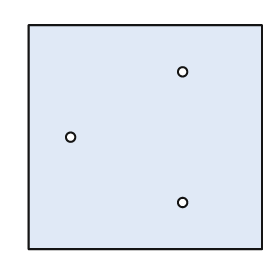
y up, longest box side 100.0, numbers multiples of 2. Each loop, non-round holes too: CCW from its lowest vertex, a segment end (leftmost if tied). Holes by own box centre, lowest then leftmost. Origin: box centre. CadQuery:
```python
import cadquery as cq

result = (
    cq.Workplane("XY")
    .moveTo(-50.0, -48.0)
    .lineTo(50.0, -48.0)
    .lineTo(50.0, 48.0)
    .lineTo(-50.0, 48.0)
    .close()
    .moveTo(16.0, -28.0)
    .circle(2.0)
    .moveTo(-32.0, 0.0)
    .circle(2.0)
    .moveTo(16.0, 28.0)
    .circle(2.0)
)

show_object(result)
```